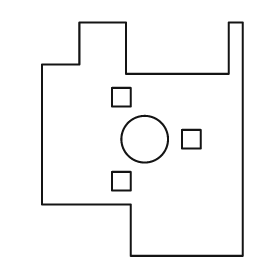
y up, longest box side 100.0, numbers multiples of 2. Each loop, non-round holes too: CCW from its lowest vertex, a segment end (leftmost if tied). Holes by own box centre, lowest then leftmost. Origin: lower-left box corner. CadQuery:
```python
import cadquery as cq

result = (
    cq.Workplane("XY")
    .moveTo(38.0, 0.0)
    .lineTo(86.0, 0.0)
    .lineTo(86.0, 100.0)
    .lineTo(80.0, 100.0)
    .lineTo(80.0, 78.0)
    .lineTo(36.0, 78.0)
    .lineTo(36.0, 100.0)
    .lineTo(16.0, 100.0)
    .lineTo(16.0, 82.0)
    .lineTo(0.0, 82.0)
    .lineTo(0.0, 22.0)
    .lineTo(38.0, 22.0)
    .close()
    .moveTo(30.0, 28.0)
    .lineTo(38.0, 28.0)
    .lineTo(38.0, 36.0)
    .lineTo(30.0, 36.0)
    .close()
    .moveTo(44.0, 50.0)
    .circle(10.0)
    .moveTo(60.0, 46.0)
    .lineTo(68.0, 46.0)
    .lineTo(68.0, 54.0)
    .lineTo(60.0, 54.0)
    .close()
    .moveTo(30.0, 64.0)
    .lineTo(38.0, 64.0)
    .lineTo(38.0, 72.0)
    .lineTo(30.0, 72.0)
    .close()
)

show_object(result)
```